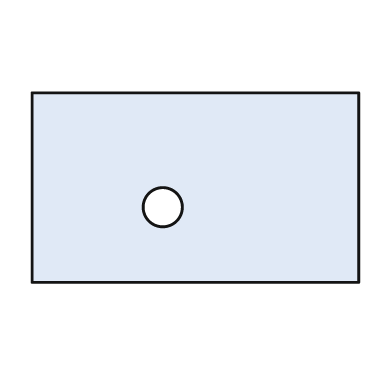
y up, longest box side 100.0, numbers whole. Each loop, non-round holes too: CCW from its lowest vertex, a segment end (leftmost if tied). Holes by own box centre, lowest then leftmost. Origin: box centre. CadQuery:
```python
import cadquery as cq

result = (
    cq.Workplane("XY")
    .moveTo(-50.0, -29.0)
    .lineTo(50.0, -29.0)
    .lineTo(50.0, 29.0)
    .lineTo(-50.0, 29.0)
    .close()
    .moveTo(-10.0, -6.0)
    .circle(6.0)
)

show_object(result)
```